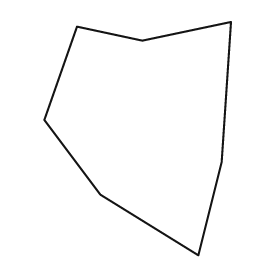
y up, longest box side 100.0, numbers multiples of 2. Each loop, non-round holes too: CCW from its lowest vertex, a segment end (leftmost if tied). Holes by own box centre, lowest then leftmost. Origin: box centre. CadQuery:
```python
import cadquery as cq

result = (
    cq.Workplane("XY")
    .moveTo(26.0, -50.0)
    .lineTo(36.0, -10.0)
    .lineTo(40.0, 50.0)
    .lineTo(2.0, 42.0)
    .lineTo(-26.0, 48.0)
    .lineTo(-40.0, 8.0)
    .lineTo(-16.0, -24.0)
    .close()
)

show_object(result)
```